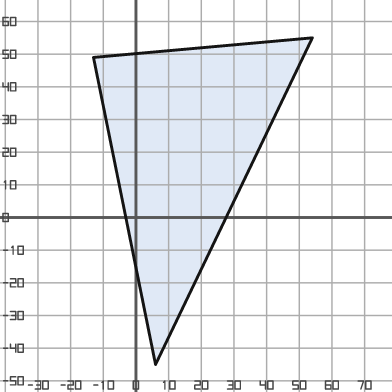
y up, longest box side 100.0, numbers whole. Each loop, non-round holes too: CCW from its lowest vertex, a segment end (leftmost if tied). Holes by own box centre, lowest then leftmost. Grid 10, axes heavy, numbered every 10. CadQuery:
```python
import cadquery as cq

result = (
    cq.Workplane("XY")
    .moveTo(6.0, -45.0)
    .lineTo(54.0, 55.0)
    .lineTo(-13.0, 49.0)
    .close()
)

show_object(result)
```